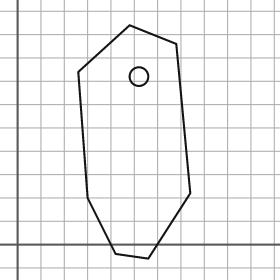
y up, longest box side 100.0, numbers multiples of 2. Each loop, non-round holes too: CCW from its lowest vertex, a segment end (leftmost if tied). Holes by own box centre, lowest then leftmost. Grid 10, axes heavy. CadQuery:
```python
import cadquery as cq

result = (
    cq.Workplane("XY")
    .moveTo(56.0, -6.0)
    .lineTo(74.0, 22.0)
    .lineTo(68.0, 86.0)
    .lineTo(48.0, 94.0)
    .lineTo(26.0, 74.0)
    .lineTo(30.0, 20.0)
    .lineTo(42.0, -4.0)
    .close()
    .moveTo(52.0, 72.0)
    .circle(4.0)
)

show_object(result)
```